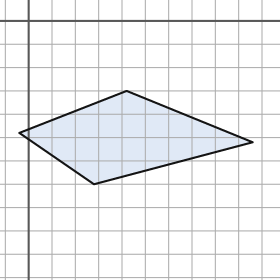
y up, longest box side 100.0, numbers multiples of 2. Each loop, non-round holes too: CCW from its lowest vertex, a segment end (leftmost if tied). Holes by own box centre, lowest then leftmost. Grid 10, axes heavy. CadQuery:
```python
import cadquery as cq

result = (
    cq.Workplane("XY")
    .moveTo(28.0, -70.0)
    .lineTo(96.0, -52.0)
    .lineTo(42.0, -30.0)
    .lineTo(-4.0, -48.0)
    .close()
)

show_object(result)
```